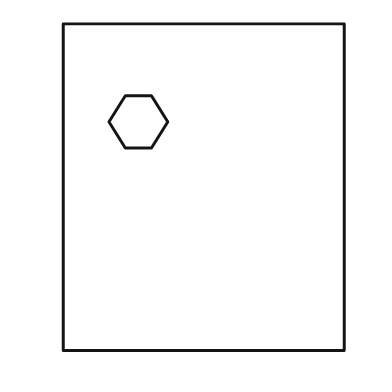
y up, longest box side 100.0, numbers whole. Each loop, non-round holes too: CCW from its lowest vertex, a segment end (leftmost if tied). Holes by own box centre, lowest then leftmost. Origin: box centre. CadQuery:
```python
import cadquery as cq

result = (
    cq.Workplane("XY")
    .moveTo(-43.0, -50.0)
    .lineTo(43.0, -50.0)
    .lineTo(43.0, 50.0)
    .lineTo(-43.0, 50.0)
    .close()
    .moveTo(-24.0, 12.0)
    .lineTo(-16.0, 12.0)
    .lineTo(-11.0, 20.0)
    .lineTo(-16.0, 28.0)
    .lineTo(-24.0, 28.0)
    .lineTo(-29.0, 20.0)
    .close()
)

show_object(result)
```